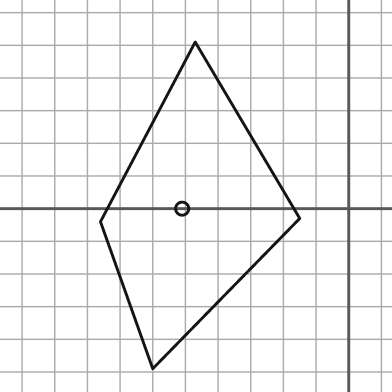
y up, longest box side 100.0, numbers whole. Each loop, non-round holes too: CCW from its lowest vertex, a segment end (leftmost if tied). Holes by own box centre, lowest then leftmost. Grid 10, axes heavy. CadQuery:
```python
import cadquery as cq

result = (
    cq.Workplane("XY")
    .moveTo(-60.0, -49.0)
    .lineTo(-15.0, -3.0)
    .lineTo(-47.0, 51.0)
    .lineTo(-76.0, -4.0)
    .close()
    .moveTo(-51.0, 0.0)
    .circle(2.0)
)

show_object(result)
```